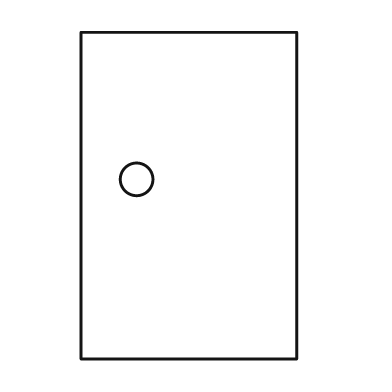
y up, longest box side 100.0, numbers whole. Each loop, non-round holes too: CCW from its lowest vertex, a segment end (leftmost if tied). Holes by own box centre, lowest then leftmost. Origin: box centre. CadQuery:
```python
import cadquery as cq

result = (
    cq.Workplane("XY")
    .moveTo(-33.0, -50.0)
    .lineTo(33.0, -50.0)
    .lineTo(33.0, 50.0)
    .lineTo(-33.0, 50.0)
    .close()
    .moveTo(-16.0, 5.0)
    .circle(5.0)
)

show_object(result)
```